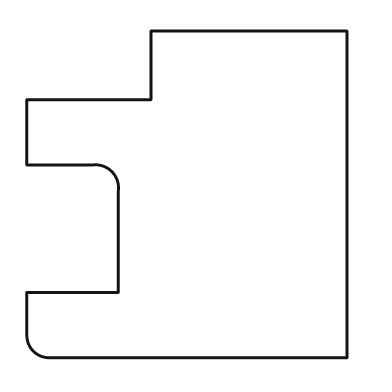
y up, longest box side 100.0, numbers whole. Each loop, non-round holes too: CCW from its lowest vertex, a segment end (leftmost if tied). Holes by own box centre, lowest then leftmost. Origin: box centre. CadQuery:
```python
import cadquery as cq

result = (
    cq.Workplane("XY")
    .moveTo(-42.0, -50.0)
    .lineTo(49.0, -50.0)
    .lineTo(49.0, 50.0)
    .lineTo(-11.0, 50.0)
    .lineTo(-11.0, 29.0)
    .lineTo(-49.0, 29.0)
    .lineTo(-49.0, 9.0)
    .lineTo(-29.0, 9.0)
    .threePointArc((-23.0, 7.0), (-21.0, 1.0))
    .lineTo(-21.0, -30.0)
    .lineTo(-49.0, -30.0)
    .lineTo(-49.0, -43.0)
    .threePointArc((-47.0, -48.0), (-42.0, -50.0))
    .close()
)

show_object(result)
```